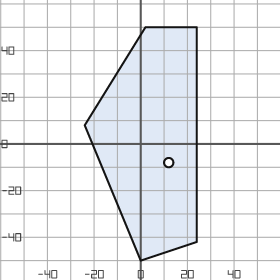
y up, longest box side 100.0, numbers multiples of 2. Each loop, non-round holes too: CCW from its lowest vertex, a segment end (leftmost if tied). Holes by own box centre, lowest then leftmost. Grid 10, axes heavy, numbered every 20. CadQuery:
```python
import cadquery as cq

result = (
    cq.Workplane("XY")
    .moveTo(0.0, -50.0)
    .lineTo(24.0, -42.0)
    .lineTo(24.0, 50.0)
    .lineTo(2.0, 50.0)
    .lineTo(-24.0, 8.0)
    .close()
    .moveTo(12.0, -8.0)
    .circle(2.0)
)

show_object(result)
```